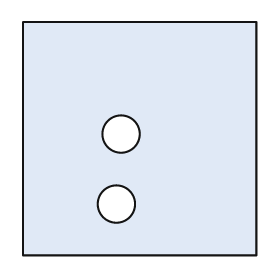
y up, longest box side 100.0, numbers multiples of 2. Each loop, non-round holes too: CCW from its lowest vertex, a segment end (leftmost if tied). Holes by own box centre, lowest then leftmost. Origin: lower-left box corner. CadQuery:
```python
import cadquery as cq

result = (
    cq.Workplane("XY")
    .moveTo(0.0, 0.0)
    .lineTo(100.0, 0.0)
    .lineTo(100.0, 100.0)
    .lineTo(0.0, 100.0)
    .close()
    .moveTo(40.0, 22.0)
    .circle(8.0)
    .moveTo(42.0, 52.0)
    .circle(8.0)
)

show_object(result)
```